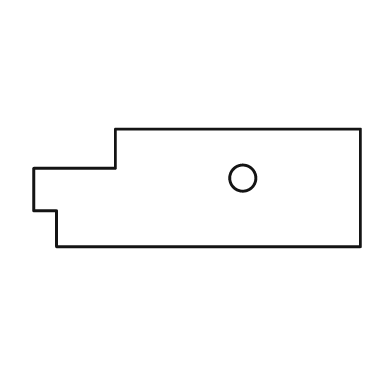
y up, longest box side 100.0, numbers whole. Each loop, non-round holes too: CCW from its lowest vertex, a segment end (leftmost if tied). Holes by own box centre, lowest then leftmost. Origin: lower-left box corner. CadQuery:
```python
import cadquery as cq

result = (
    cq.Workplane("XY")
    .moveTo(7.0, 0.0)
    .lineTo(100.0, 0.0)
    .lineTo(100.0, 36.0)
    .lineTo(25.0, 36.0)
    .lineTo(25.0, 24.0)
    .lineTo(0.0, 24.0)
    .lineTo(0.0, 11.0)
    .lineTo(7.0, 11.0)
    .close()
    .moveTo(64.0, 21.0)
    .circle(4.0)
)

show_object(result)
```